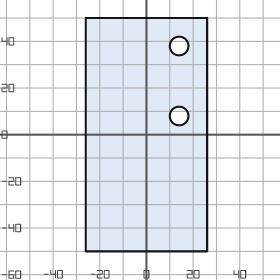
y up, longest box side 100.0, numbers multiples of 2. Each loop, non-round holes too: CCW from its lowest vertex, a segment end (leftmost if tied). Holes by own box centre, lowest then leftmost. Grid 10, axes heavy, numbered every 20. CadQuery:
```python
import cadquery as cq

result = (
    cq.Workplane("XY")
    .moveTo(-26.0, -50.0)
    .lineTo(26.0, -50.0)
    .lineTo(26.0, 50.0)
    .lineTo(-26.0, 50.0)
    .close()
    .moveTo(14.0, 8.0)
    .circle(4.0)
    .moveTo(14.0, 38.0)
    .circle(4.0)
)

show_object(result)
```